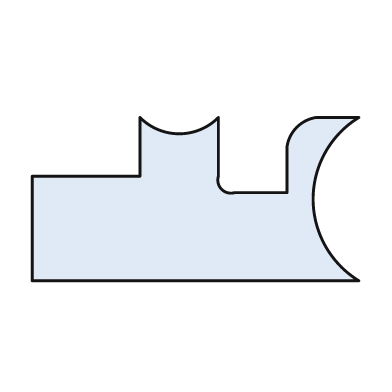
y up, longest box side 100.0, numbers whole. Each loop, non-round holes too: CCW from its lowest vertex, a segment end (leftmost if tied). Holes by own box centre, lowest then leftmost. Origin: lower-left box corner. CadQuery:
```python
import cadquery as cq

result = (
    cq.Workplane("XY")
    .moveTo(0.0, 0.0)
    .lineTo(100.0, 0.0)
    .threePointArc((86.0, 25.0), (100.0, 50.0))
    .lineTo(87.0, 50.0)
    .threePointArc((81.0, 47.0), (78.0, 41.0))
    .lineTo(78.0, 27.0)
    .lineTo(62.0, 27.0)
    .threePointArc((58.0, 28.0), (57.0, 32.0))
    .lineTo(57.0, 50.0)
    .threePointArc((45.0, 45.0), (33.0, 50.0))
    .lineTo(33.0, 32.0)
    .lineTo(0.0, 32.0)
    .close()
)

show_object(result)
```